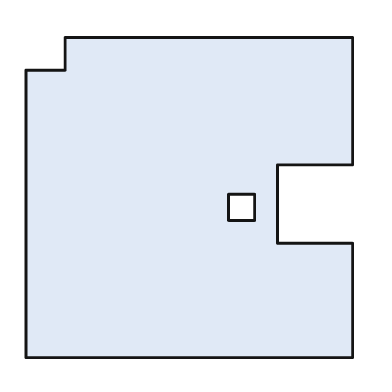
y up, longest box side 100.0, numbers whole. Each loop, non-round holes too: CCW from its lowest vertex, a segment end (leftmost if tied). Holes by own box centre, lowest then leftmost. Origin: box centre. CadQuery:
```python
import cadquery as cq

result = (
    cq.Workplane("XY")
    .moveTo(-50.0, -49.0)
    .lineTo(50.0, -49.0)
    .lineTo(50.0, -14.0)
    .lineTo(27.0, -14.0)
    .lineTo(27.0, 10.0)
    .lineTo(50.0, 10.0)
    .lineTo(50.0, 49.0)
    .lineTo(-38.0, 49.0)
    .lineTo(-38.0, 39.0)
    .lineTo(-50.0, 39.0)
    .close()
    .moveTo(12.0, -7.0)
    .lineTo(20.0, -7.0)
    .lineTo(20.0, 1.0)
    .lineTo(12.0, 1.0)
    .close()
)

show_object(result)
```